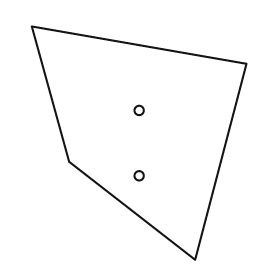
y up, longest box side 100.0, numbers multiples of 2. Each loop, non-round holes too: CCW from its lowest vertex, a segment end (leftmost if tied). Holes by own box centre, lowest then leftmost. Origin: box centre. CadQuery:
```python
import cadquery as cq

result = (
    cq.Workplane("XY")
    .moveTo(24.0, -50.0)
    .lineTo(46.0, 34.0)
    .lineTo(-46.0, 50.0)
    .lineTo(-30.0, -8.0)
    .close()
    .moveTo(0.0, -14.0)
    .circle(2.0)
    .moveTo(0.0, 14.0)
    .circle(2.0)
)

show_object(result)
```